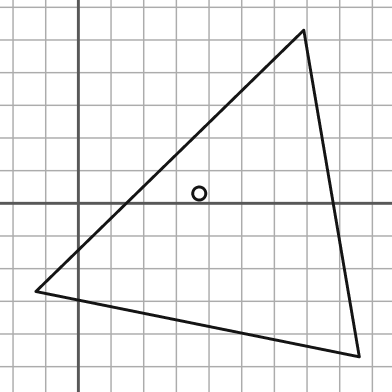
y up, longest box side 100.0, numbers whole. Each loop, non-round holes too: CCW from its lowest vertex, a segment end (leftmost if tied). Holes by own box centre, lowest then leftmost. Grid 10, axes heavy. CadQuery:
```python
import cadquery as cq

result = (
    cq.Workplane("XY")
    .moveTo(86.0, -47.0)
    .lineTo(69.0, 53.0)
    .lineTo(-13.0, -27.0)
    .close()
    .moveTo(37.0, 3.0)
    .circle(2.0)
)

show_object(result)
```